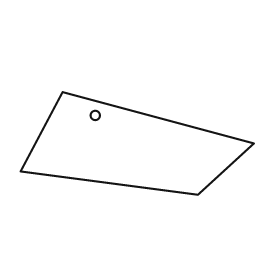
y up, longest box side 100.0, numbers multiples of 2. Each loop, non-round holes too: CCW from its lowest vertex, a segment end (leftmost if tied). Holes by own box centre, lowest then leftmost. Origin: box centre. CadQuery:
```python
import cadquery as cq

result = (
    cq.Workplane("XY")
    .moveTo(26.0, -22.0)
    .lineTo(50.0, 0.0)
    .lineTo(-32.0, 22.0)
    .lineTo(-50.0, -12.0)
    .close()
    .moveTo(-18.0, 12.0)
    .circle(2.0)
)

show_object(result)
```